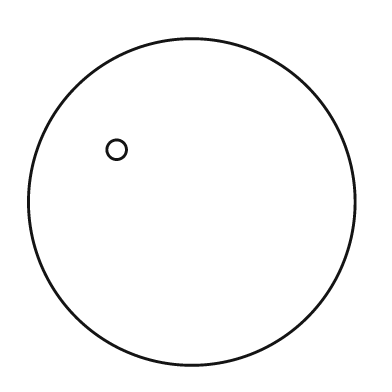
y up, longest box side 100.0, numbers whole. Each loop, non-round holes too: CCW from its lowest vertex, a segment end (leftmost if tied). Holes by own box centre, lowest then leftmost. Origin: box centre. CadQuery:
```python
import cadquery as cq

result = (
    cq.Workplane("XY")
    .moveTo(0.0, 0.0)
    .circle(50.0)
    .moveTo(-23.0, 16.0)
    .circle(3.0)
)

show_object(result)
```